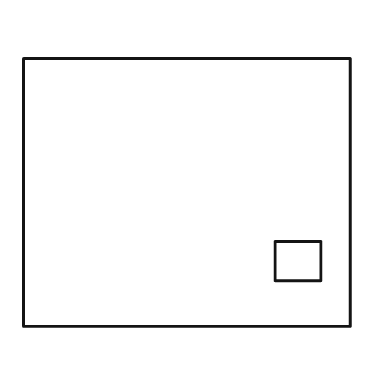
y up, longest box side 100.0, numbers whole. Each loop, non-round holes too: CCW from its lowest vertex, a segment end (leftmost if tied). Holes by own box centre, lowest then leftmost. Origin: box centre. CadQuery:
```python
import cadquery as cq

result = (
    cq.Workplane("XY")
    .moveTo(-50.0, -41.0)
    .lineTo(50.0, -41.0)
    .lineTo(50.0, 41.0)
    .lineTo(-50.0, 41.0)
    .close()
    .moveTo(27.0, -27.0)
    .lineTo(41.0, -27.0)
    .lineTo(41.0, -15.0)
    .lineTo(27.0, -15.0)
    .close()
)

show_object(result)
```